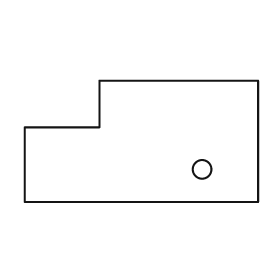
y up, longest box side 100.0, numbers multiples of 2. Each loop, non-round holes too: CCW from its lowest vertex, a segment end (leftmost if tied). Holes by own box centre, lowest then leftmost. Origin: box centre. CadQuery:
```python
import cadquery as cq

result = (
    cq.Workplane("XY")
    .moveTo(-50.0, -26.0)
    .lineTo(50.0, -26.0)
    .lineTo(50.0, 26.0)
    .lineTo(-18.0, 26.0)
    .lineTo(-18.0, 6.0)
    .lineTo(-50.0, 6.0)
    .close()
    .moveTo(26.0, -12.0)
    .circle(4.0)
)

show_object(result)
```